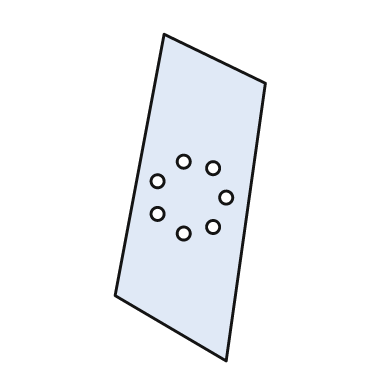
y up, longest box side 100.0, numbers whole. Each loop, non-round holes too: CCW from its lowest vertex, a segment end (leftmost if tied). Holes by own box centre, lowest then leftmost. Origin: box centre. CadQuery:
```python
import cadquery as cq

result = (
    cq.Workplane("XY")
    .moveTo(11.0, -50.0)
    .lineTo(23.0, 35.0)
    .lineTo(-8.0, 50.0)
    .lineTo(-23.0, -30.0)
    .close()
    .moveTo(-2.0, -11.0)
    .circle(2.0)
    .moveTo(7.0, -9.0)
    .circle(2.0)
    .moveTo(-10.0, -5.0)
    .circle(2.0)
    .moveTo(11.0, 0.0)
    .circle(2.0)
    .moveTo(-10.0, 5.0)
    .circle(2.0)
    .moveTo(7.0, 9.0)
    .circle(2.0)
    .moveTo(-2.0, 11.0)
    .circle(2.0)
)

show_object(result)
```